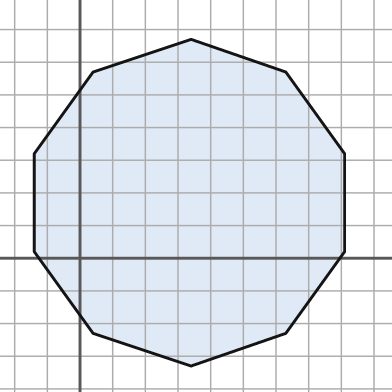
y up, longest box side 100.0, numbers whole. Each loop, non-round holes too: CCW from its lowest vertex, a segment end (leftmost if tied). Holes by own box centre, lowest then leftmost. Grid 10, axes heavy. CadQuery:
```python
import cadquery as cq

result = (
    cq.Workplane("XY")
    .moveTo(34.0, -33.0)
    .lineTo(63.0, -23.0)
    .lineTo(81.0, 2.0)
    .lineTo(81.0, 32.0)
    .lineTo(63.0, 57.0)
    .lineTo(34.0, 67.0)
    .lineTo(4.0, 57.0)
    .lineTo(-14.0, 32.0)
    .lineTo(-14.0, 2.0)
    .lineTo(4.0, -23.0)
    .close()
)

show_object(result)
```